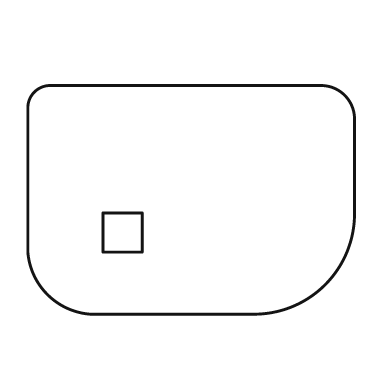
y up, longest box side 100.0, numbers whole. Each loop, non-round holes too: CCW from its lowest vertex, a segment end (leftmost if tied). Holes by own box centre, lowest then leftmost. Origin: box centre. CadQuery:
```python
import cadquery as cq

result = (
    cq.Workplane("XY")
    .moveTo(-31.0, -35.0)
    .lineTo(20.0, -35.0)
    .threePointArc((41.0, -26.0), (50.0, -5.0))
    .lineTo(50.0, 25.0)
    .threePointArc((47.0, 32.0), (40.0, 35.0))
    .lineTo(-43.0, 35.0)
    .threePointArc((-48.0, 33.0), (-50.0, 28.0))
    .lineTo(-50.0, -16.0)
    .threePointArc((-44.0, -29.0), (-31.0, -35.0))
    .close()
    .moveTo(-27.0, -16.0)
    .lineTo(-15.0, -16.0)
    .lineTo(-15.0, -4.0)
    .lineTo(-27.0, -4.0)
    .close()
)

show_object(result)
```